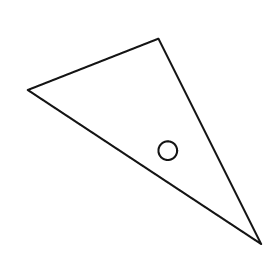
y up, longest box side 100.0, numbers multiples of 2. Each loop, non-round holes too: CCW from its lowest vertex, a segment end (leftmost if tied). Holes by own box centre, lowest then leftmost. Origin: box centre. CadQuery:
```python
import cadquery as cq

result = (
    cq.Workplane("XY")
    .moveTo(50.0, -44.0)
    .lineTo(6.0, 44.0)
    .lineTo(-50.0, 22.0)
    .close()
    .moveTo(10.0, -4.0)
    .circle(4.0)
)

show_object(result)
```